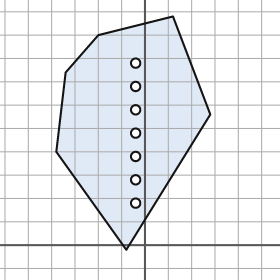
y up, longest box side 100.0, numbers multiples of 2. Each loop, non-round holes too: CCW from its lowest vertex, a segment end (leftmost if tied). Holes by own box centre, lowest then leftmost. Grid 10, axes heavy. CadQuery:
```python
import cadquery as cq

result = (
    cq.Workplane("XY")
    .moveTo(-8.0, -2.0)
    .lineTo(28.0, 56.0)
    .lineTo(12.0, 98.0)
    .lineTo(-20.0, 90.0)
    .lineTo(-34.0, 74.0)
    .lineTo(-38.0, 40.0)
    .close()
    .moveTo(-4.0, 18.0)
    .circle(2.0)
    .moveTo(-4.0, 28.0)
    .circle(2.0)
    .moveTo(-4.0, 38.0)
    .circle(2.0)
    .moveTo(-4.0, 48.0)
    .circle(2.0)
    .moveTo(-4.0, 58.0)
    .circle(2.0)
    .moveTo(-4.0, 68.0)
    .circle(2.0)
    .moveTo(-4.0, 78.0)
    .circle(2.0)
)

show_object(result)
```